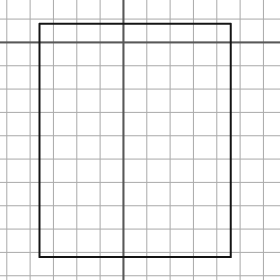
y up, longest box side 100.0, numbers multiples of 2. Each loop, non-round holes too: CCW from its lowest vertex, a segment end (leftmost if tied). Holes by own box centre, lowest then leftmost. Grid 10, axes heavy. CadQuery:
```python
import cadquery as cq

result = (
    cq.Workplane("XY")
    .moveTo(-36.0, -92.0)
    .lineTo(46.0, -92.0)
    .lineTo(46.0, 8.0)
    .lineTo(-36.0, 8.0)
    .close()
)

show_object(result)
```